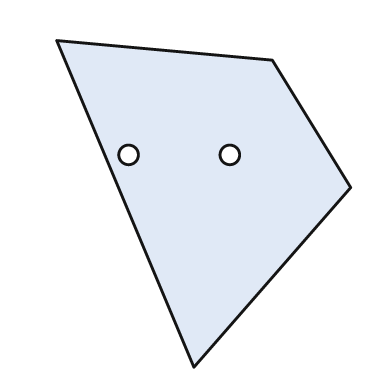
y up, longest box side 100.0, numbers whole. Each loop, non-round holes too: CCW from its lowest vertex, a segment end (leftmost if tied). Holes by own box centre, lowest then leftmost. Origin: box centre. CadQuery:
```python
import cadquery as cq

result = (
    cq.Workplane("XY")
    .moveTo(-3.0, -50.0)
    .lineTo(45.0, 5.0)
    .lineTo(21.0, 44.0)
    .lineTo(-45.0, 50.0)
    .close()
    .moveTo(-23.0, 15.0)
    .circle(3.0)
    .moveTo(8.0, 15.0)
    .circle(3.0)
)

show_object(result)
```